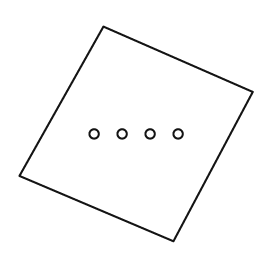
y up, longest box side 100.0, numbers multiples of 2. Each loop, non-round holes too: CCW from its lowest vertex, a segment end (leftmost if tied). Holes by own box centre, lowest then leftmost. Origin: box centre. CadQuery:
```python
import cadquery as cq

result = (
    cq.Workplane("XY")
    .moveTo(16.0, -46.0)
    .lineTo(50.0, 18.0)
    .lineTo(-14.0, 46.0)
    .lineTo(-50.0, -18.0)
    .close()
    .moveTo(-18.0, 0.0)
    .circle(2.0)
    .moveTo(-6.0, 0.0)
    .circle(2.0)
    .moveTo(6.0, 0.0)
    .circle(2.0)
    .moveTo(18.0, 0.0)
    .circle(2.0)
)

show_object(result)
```